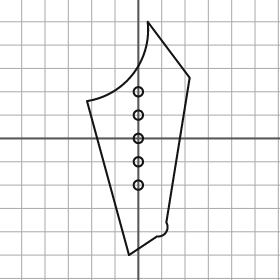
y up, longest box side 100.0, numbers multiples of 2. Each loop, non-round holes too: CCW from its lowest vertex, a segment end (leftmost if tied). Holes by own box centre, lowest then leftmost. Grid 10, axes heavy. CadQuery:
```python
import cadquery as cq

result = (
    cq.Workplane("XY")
    .moveTo(-4.0, -50.0)
    .lineTo(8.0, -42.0)
    .threePointArc((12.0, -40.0), (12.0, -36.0))
    .lineTo(22.0, 26.0)
    .lineTo(4.0, 50.0)
    .threePointArc((-2.0, 28.0), (-22.0, 16.0))
    .close()
    .moveTo(0.0, -20.0)
    .circle(2.0)
    .moveTo(0.0, -10.0)
    .circle(2.0)
    .moveTo(0.0, 0.0)
    .circle(2.0)
    .moveTo(0.0, 10.0)
    .circle(2.0)
    .moveTo(0.0, 20.0)
    .circle(2.0)
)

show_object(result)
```